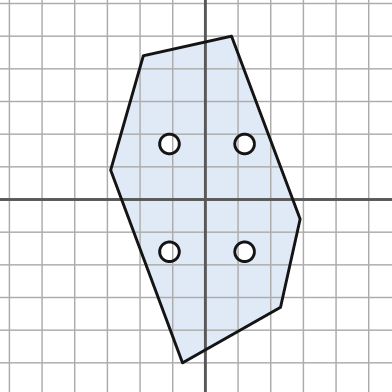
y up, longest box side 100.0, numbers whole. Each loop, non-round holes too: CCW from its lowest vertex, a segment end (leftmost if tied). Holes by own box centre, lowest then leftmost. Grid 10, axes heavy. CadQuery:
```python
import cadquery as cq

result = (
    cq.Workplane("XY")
    .moveTo(-7.0, -50.0)
    .lineTo(23.0, -33.0)
    .lineTo(29.0, -6.0)
    .lineTo(8.0, 50.0)
    .lineTo(-19.0, 44.0)
    .lineTo(-29.0, 9.0)
    .close()
    .moveTo(-11.0, -16.0)
    .circle(3.0)
    .moveTo(12.0, -16.0)
    .circle(3.0)
    .moveTo(-11.0, 17.0)
    .circle(3.0)
    .moveTo(12.0, 17.0)
    .circle(3.0)
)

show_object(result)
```